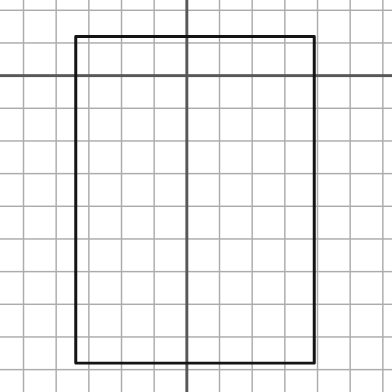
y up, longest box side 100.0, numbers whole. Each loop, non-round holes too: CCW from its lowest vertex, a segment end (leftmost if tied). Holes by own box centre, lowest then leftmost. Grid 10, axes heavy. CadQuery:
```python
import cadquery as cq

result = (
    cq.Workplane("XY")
    .moveTo(-34.0, -88.0)
    .lineTo(39.0, -88.0)
    .lineTo(39.0, 12.0)
    .lineTo(-34.0, 12.0)
    .close()
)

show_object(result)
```